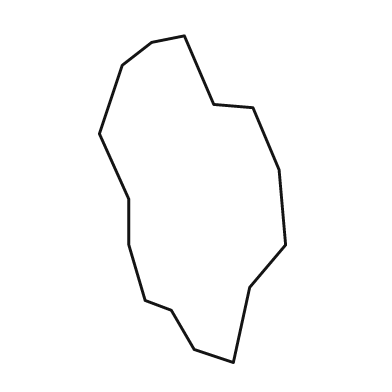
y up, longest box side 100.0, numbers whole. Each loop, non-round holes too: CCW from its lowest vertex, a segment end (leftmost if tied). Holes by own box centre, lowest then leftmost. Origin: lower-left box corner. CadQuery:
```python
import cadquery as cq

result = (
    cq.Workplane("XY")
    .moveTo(41.0, 0.0)
    .lineTo(46.0, 23.0)
    .lineTo(57.0, 36.0)
    .lineTo(55.0, 59.0)
    .lineTo(47.0, 78.0)
    .lineTo(35.0, 79.0)
    .lineTo(26.0, 100.0)
    .lineTo(16.0, 98.0)
    .lineTo(7.0, 91.0)
    .lineTo(0.0, 70.0)
    .lineTo(9.0, 50.0)
    .lineTo(9.0, 36.0)
    .lineTo(14.0, 19.0)
    .lineTo(22.0, 16.0)
    .lineTo(29.0, 4.0)
    .close()
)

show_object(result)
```